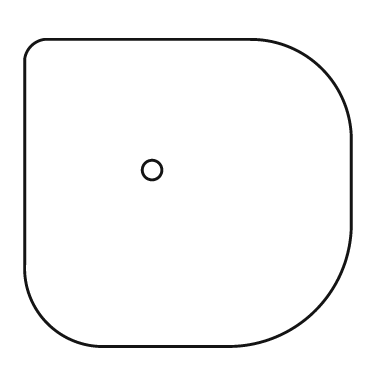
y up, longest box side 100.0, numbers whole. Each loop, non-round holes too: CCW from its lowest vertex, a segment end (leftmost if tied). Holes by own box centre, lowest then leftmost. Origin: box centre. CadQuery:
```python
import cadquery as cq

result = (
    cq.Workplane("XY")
    .moveTo(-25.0, -47.0)
    .lineTo(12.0, -47.0)
    .threePointArc((39.0, -36.0), (50.0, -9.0))
    .lineTo(50.0, 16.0)
    .threePointArc((41.0, 38.0), (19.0, 47.0))
    .lineTo(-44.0, 47.0)
    .threePointArc((-48.0, 45.0), (-50.0, 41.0))
    .lineTo(-50.0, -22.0)
    .threePointArc((-43.0, -40.0), (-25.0, -47.0))
    .close()
    .moveTo(-11.0, 7.0)
    .circle(3.0)
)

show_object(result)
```